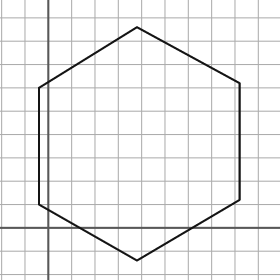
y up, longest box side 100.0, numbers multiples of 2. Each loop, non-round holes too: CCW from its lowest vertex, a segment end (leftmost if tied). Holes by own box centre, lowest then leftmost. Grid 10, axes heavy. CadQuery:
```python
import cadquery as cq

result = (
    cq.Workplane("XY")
    .moveTo(38.0, -14.0)
    .lineTo(82.0, 12.0)
    .lineTo(82.0, 62.0)
    .lineTo(38.0, 86.0)
    .lineTo(-4.0, 60.0)
    .lineTo(-4.0, 10.0)
    .close()
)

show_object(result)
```